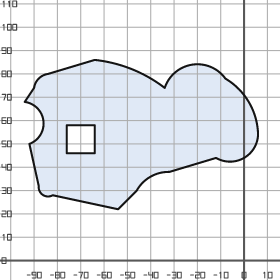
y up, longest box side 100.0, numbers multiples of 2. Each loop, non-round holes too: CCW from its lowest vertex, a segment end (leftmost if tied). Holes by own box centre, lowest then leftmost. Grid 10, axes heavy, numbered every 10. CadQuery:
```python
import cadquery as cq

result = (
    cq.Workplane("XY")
    .moveTo(-54.0, 22.0)
    .lineTo(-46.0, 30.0)
    .threePointArc((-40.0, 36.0), (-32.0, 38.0))
    .lineTo(-12.0, 44.0)
    .threePointArc((0.0, 44.0), (6.0, 54.0))
    .threePointArc((2.0, 68.0), (-8.0, 78.0))
    .threePointArc((-22.0, 84.0), (-34.0, 74.0))
    .threePointArc((-48.0, 82.0), (-64.0, 86.0))
    .lineTo(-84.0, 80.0)
    .threePointArc((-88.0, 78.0), (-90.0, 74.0))
    .lineTo(-94.0, 68.0)
    .threePointArc((-86.0, 60.0), (-92.0, 50.0))
    .lineTo(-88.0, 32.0)
    .threePointArc((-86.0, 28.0), (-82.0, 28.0))
    .close()
    .moveTo(-76.0, 46.0)
    .lineTo(-64.0, 46.0)
    .lineTo(-64.0, 58.0)
    .lineTo(-76.0, 58.0)
    .close()
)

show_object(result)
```